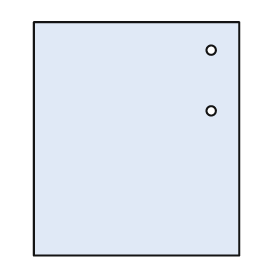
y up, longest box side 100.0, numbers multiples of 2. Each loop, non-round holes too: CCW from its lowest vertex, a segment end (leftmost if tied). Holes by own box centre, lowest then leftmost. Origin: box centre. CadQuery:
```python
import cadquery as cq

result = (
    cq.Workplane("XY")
    .moveTo(-44.0, -50.0)
    .lineTo(44.0, -50.0)
    .lineTo(44.0, 50.0)
    .lineTo(-44.0, 50.0)
    .close()
    .moveTo(32.0, 12.0)
    .circle(2.0)
    .moveTo(32.0, 38.0)
    .circle(2.0)
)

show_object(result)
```